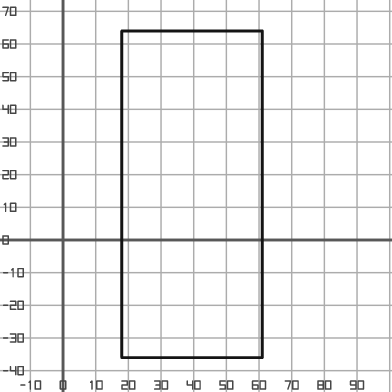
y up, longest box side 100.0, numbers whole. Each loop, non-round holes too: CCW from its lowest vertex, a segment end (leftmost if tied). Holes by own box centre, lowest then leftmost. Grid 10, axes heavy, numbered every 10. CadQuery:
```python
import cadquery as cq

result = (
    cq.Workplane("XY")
    .moveTo(18.0, -36.0)
    .lineTo(61.0, -36.0)
    .lineTo(61.0, 64.0)
    .lineTo(18.0, 64.0)
    .close()
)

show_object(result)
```